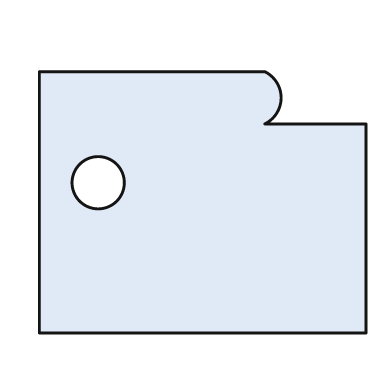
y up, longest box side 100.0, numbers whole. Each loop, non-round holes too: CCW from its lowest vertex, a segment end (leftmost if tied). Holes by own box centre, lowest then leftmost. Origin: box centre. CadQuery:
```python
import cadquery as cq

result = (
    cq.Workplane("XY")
    .moveTo(-50.0, -40.0)
    .lineTo(50.0, -40.0)
    .lineTo(50.0, 24.0)
    .lineTo(19.0, 24.0)
    .threePointArc((24.0, 32.0), (19.0, 40.0))
    .lineTo(-50.0, 40.0)
    .close()
    .moveTo(-32.0, 6.0)
    .circle(8.0)
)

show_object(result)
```